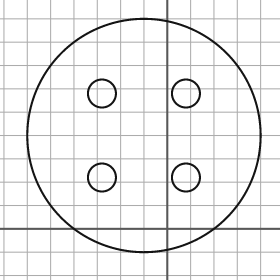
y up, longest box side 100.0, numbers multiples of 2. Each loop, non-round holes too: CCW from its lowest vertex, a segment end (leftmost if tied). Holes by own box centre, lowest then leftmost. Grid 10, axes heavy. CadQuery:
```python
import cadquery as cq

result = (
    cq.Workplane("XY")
    .moveTo(-10.0, 40.0)
    .circle(50.0)
    .moveTo(-28.0, 22.0)
    .circle(6.0)
    .moveTo(8.0, 22.0)
    .circle(6.0)
    .moveTo(-28.0, 58.0)
    .circle(6.0)
    .moveTo(8.0, 58.0)
    .circle(6.0)
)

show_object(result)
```